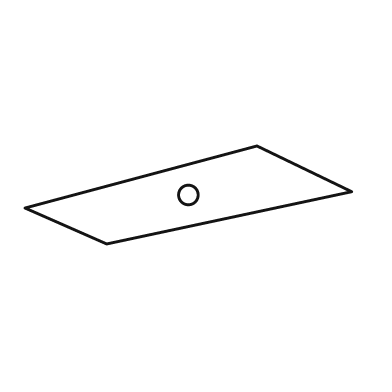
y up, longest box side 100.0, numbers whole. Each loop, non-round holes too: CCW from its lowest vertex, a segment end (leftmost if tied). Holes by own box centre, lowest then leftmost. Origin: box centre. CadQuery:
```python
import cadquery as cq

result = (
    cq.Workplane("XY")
    .moveTo(-25.0, -15.0)
    .lineTo(50.0, 1.0)
    .lineTo(21.0, 15.0)
    .lineTo(-50.0, -4.0)
    .close()
    .moveTo(0.0, 0.0)
    .circle(3.0)
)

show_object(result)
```